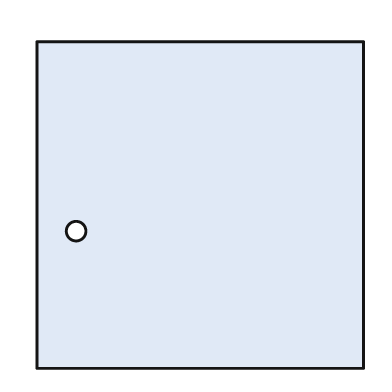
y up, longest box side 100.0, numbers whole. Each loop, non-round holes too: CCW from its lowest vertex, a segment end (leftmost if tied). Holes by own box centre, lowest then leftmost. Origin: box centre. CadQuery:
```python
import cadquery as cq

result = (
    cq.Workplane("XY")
    .moveTo(-50.0, -50.0)
    .lineTo(50.0, -50.0)
    .lineTo(50.0, 50.0)
    .lineTo(-50.0, 50.0)
    .close()
    .moveTo(-38.0, -8.0)
    .circle(3.0)
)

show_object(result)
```